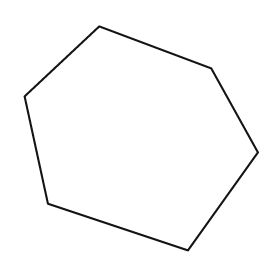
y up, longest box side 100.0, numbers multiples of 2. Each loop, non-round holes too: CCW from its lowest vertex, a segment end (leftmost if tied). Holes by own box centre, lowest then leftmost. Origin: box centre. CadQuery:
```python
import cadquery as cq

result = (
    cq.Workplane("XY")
    .moveTo(20.0, -48.0)
    .lineTo(50.0, -6.0)
    .lineTo(30.0, 30.0)
    .lineTo(-18.0, 48.0)
    .lineTo(-50.0, 18.0)
    .lineTo(-40.0, -28.0)
    .close()
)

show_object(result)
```